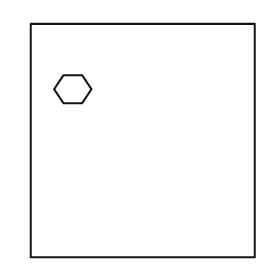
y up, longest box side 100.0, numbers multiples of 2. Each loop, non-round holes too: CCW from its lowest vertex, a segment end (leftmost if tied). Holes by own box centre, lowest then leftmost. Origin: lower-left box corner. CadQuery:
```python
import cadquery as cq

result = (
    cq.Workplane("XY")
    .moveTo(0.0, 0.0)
    .lineTo(96.0, 0.0)
    .lineTo(96.0, 100.0)
    .lineTo(0.0, 100.0)
    .close()
    .moveTo(14.0, 66.0)
    .lineTo(22.0, 66.0)
    .lineTo(26.0, 72.0)
    .lineTo(22.0, 78.0)
    .lineTo(14.0, 78.0)
    .lineTo(10.0, 72.0)
    .close()
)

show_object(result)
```